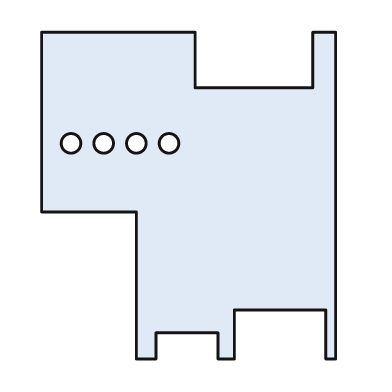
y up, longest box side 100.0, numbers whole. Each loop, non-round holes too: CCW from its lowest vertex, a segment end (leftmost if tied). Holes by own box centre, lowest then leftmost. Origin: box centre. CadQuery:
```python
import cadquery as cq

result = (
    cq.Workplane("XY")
    .moveTo(-16.0, -50.0)
    .lineTo(-10.0, -50.0)
    .lineTo(-10.0, -42.0)
    .lineTo(9.0, -42.0)
    .lineTo(9.0, -50.0)
    .lineTo(14.0, -50.0)
    .lineTo(14.0, -35.0)
    .lineTo(42.0, -35.0)
    .lineTo(42.0, -50.0)
    .lineTo(45.0, -50.0)
    .lineTo(45.0, 50.0)
    .lineTo(38.0, 50.0)
    .lineTo(38.0, 33.0)
    .lineTo(2.0, 33.0)
    .lineTo(2.0, 50.0)
    .lineTo(-45.0, 50.0)
    .lineTo(-45.0, -5.0)
    .lineTo(-16.0, -5.0)
    .close()
    .moveTo(-36.0, 16.0)
    .circle(3.0)
    .moveTo(-26.0, 16.0)
    .circle(3.0)
    .moveTo(-16.0, 16.0)
    .circle(3.0)
    .moveTo(-6.0, 16.0)
    .circle(3.0)
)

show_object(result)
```